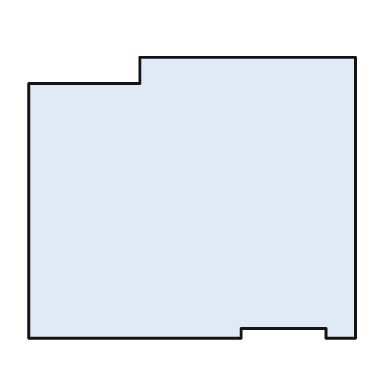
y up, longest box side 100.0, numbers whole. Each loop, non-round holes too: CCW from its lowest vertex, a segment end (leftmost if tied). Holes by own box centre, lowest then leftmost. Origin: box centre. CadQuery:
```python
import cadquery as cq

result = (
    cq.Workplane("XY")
    .moveTo(-50.0, -43.0)
    .lineTo(15.0, -43.0)
    .lineTo(15.0, -40.0)
    .lineTo(41.0, -40.0)
    .lineTo(41.0, -43.0)
    .lineTo(50.0, -43.0)
    .lineTo(50.0, 43.0)
    .lineTo(-16.0, 43.0)
    .lineTo(-16.0, 35.0)
    .lineTo(-50.0, 35.0)
    .close()
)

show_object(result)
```